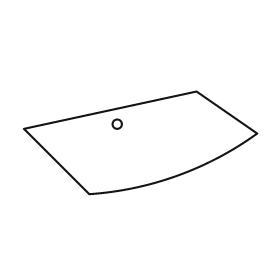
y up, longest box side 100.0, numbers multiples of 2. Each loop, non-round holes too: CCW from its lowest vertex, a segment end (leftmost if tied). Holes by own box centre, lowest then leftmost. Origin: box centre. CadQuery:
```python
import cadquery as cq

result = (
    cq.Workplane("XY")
    .moveTo(-22.0, -22.0)
    .threePointArc((16.0, -14.0), (50.0, 4.0))
    .lineTo(24.0, 22.0)
    .lineTo(-50.0, 6.0)
    .close()
    .moveTo(-10.0, 8.0)
    .circle(2.0)
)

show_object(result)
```